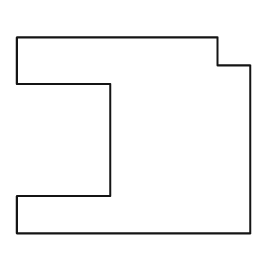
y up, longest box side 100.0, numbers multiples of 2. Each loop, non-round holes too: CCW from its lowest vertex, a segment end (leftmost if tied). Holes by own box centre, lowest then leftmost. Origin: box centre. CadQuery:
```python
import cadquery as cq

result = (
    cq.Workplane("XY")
    .moveTo(-50.0, -42.0)
    .lineTo(50.0, -42.0)
    .lineTo(50.0, 30.0)
    .lineTo(36.0, 30.0)
    .lineTo(36.0, 42.0)
    .lineTo(-50.0, 42.0)
    .lineTo(-50.0, 22.0)
    .lineTo(-10.0, 22.0)
    .lineTo(-10.0, -26.0)
    .lineTo(-50.0, -26.0)
    .close()
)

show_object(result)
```